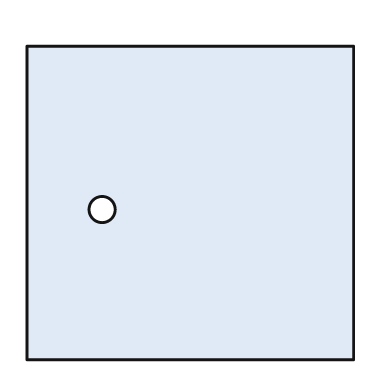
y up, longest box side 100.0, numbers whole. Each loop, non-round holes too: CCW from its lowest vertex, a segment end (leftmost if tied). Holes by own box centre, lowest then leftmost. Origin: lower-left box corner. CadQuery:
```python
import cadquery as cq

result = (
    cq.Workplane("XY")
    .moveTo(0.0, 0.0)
    .lineTo(100.0, 0.0)
    .lineTo(100.0, 96.0)
    .lineTo(0.0, 96.0)
    .close()
    .moveTo(23.0, 46.0)
    .circle(4.0)
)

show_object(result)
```